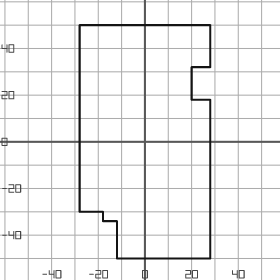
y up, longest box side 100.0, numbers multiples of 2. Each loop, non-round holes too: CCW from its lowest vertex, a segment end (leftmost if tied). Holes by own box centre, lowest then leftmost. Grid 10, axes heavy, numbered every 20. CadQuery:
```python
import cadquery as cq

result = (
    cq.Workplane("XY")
    .moveTo(-12.0, -50.0)
    .lineTo(28.0, -50.0)
    .lineTo(28.0, 18.0)
    .lineTo(20.0, 18.0)
    .lineTo(20.0, 32.0)
    .lineTo(28.0, 32.0)
    .lineTo(28.0, 50.0)
    .lineTo(-28.0, 50.0)
    .lineTo(-28.0, -30.0)
    .lineTo(-18.0, -30.0)
    .lineTo(-18.0, -34.0)
    .lineTo(-12.0, -34.0)
    .close()
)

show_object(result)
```